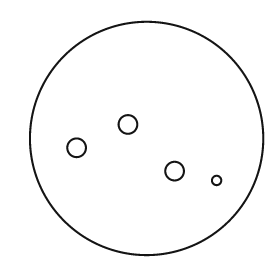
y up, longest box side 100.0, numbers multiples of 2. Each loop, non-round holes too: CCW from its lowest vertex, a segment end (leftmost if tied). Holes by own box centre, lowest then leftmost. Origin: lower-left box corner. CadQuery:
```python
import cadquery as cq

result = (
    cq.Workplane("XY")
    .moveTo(50.0, 50.0)
    .circle(50.0)
    .moveTo(80.0, 32.0)
    .circle(2.0)
    .moveTo(62.0, 36.0)
    .circle(4.0)
    .moveTo(20.0, 46.0)
    .circle(4.0)
    .moveTo(42.0, 56.0)
    .circle(4.0)
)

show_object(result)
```